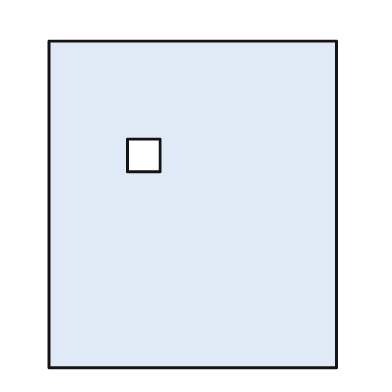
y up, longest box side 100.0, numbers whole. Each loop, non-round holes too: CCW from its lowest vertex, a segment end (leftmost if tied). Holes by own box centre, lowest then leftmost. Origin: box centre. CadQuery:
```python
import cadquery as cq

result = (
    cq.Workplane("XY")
    .moveTo(-44.0, -50.0)
    .lineTo(44.0, -50.0)
    .lineTo(44.0, 50.0)
    .lineTo(-44.0, 50.0)
    .close()
    .moveTo(-20.0, 10.0)
    .lineTo(-10.0, 10.0)
    .lineTo(-10.0, 20.0)
    .lineTo(-20.0, 20.0)
    .close()
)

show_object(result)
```